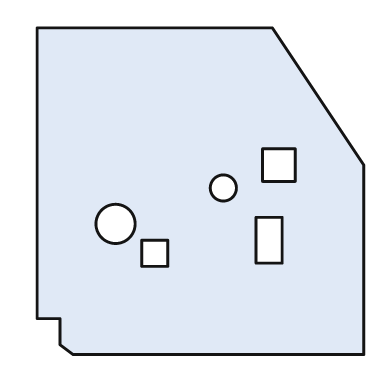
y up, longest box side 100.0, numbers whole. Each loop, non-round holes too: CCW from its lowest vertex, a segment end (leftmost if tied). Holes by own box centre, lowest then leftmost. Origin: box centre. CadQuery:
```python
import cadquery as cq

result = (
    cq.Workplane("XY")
    .moveTo(-39.0, -50.0)
    .lineTo(50.0, -50.0)
    .lineTo(50.0, 8.0)
    .lineTo(22.0, 50.0)
    .lineTo(-50.0, 50.0)
    .lineTo(-50.0, -39.0)
    .lineTo(-43.0, -39.0)
    .lineTo(-43.0, -47.0)
    .close()
    .moveTo(-18.0, -23.0)
    .lineTo(-10.0, -23.0)
    .lineTo(-10.0, -15.0)
    .lineTo(-18.0, -15.0)
    .close()
    .moveTo(17.0, -22.0)
    .lineTo(25.0, -22.0)
    .lineTo(25.0, -8.0)
    .lineTo(17.0, -8.0)
    .close()
    .moveTo(-26.0, -10.0)
    .circle(6.0)
    .moveTo(7.0, 1.0)
    .circle(4.0)
    .moveTo(19.0, 3.0)
    .lineTo(29.0, 3.0)
    .lineTo(29.0, 13.0)
    .lineTo(19.0, 13.0)
    .close()
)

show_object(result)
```